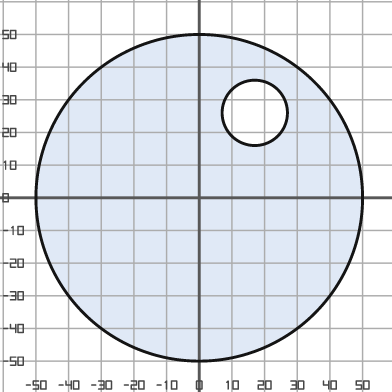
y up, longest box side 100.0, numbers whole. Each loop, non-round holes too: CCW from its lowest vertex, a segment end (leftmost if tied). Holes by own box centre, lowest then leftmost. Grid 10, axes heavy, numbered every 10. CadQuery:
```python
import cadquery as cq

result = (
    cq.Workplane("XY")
    .moveTo(0.0, 0.0)
    .circle(50.0)
    .moveTo(17.0, 26.0)
    .circle(10.0)
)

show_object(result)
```